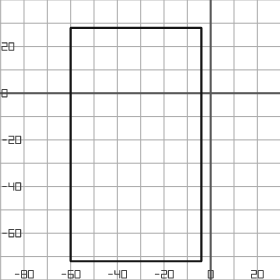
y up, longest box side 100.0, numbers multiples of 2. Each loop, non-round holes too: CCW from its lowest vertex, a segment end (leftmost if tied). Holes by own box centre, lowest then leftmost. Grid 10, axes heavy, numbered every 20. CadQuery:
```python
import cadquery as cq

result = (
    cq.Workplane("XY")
    .moveTo(-60.0, -72.0)
    .lineTo(-4.0, -72.0)
    .lineTo(-4.0, 28.0)
    .lineTo(-60.0, 28.0)
    .close()
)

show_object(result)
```